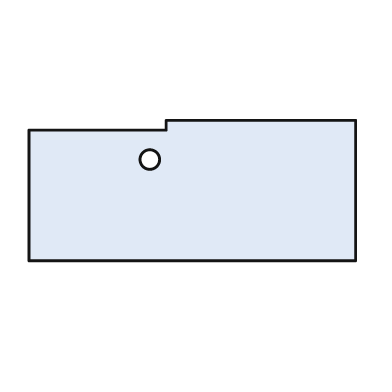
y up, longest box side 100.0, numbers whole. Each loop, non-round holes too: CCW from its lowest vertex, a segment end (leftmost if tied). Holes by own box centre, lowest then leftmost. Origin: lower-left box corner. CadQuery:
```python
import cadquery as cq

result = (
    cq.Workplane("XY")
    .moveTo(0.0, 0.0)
    .lineTo(100.0, 0.0)
    .lineTo(100.0, 43.0)
    .lineTo(42.0, 43.0)
    .lineTo(42.0, 40.0)
    .lineTo(0.0, 40.0)
    .close()
    .moveTo(37.0, 31.0)
    .circle(3.0)
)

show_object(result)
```